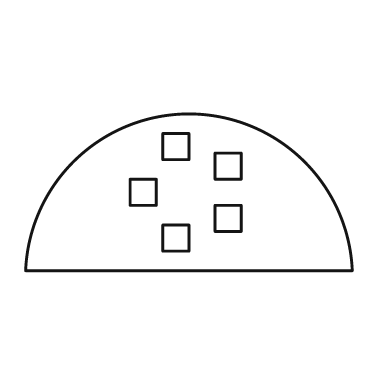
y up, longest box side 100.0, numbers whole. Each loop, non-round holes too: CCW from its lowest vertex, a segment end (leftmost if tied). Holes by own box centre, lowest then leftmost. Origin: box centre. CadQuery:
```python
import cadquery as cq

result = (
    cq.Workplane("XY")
    .moveTo(-50.0, -24.0)
    .lineTo(50.0, -24.0)
    .threePointArc((0.0, 24.0), (-50.0, -24.0))
    .close()
    .moveTo(-8.0, -18.0)
    .lineTo(0.0, -18.0)
    .lineTo(0.0, -10.0)
    .lineTo(-8.0, -10.0)
    .close()
    .moveTo(8.0, -12.0)
    .lineTo(16.0, -12.0)
    .lineTo(16.0, -4.0)
    .lineTo(8.0, -4.0)
    .close()
    .moveTo(-18.0, -4.0)
    .lineTo(-10.0, -4.0)
    .lineTo(-10.0, 4.0)
    .lineTo(-18.0, 4.0)
    .close()
    .moveTo(8.0, 4.0)
    .lineTo(16.0, 4.0)
    .lineTo(16.0, 12.0)
    .lineTo(8.0, 12.0)
    .close()
    .moveTo(-8.0, 10.0)
    .lineTo(0.0, 10.0)
    .lineTo(0.0, 18.0)
    .lineTo(-8.0, 18.0)
    .close()
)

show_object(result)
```